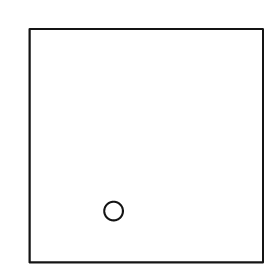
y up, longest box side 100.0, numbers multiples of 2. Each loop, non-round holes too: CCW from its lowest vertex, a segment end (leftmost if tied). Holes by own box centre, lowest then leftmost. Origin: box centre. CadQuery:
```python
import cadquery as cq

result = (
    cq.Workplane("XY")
    .moveTo(-50.0, -50.0)
    .lineTo(50.0, -50.0)
    .lineTo(50.0, 50.0)
    .lineTo(-50.0, 50.0)
    .close()
    .moveTo(-14.0, -28.0)
    .circle(4.0)
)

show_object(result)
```